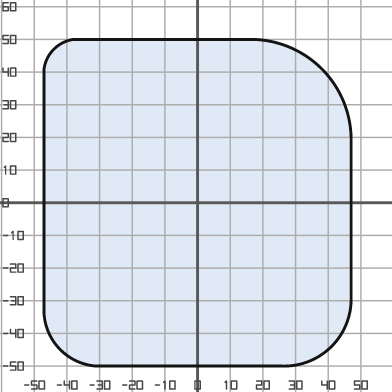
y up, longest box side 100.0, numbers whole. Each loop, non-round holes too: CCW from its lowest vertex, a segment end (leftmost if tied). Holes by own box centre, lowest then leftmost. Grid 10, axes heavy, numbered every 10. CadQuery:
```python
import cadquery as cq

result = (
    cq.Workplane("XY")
    .moveTo(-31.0, -50.0)
    .lineTo(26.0, -50.0)
    .threePointArc((41.0, -44.0), (47.0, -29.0))
    .lineTo(47.0, 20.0)
    .threePointArc((38.0, 41.0), (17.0, 50.0))
    .lineTo(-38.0, 50.0)
    .threePointArc((-44.0, 47.0), (-47.0, 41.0))
    .lineTo(-47.0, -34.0)
    .threePointArc((-42.0, -45.0), (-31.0, -50.0))
    .close()
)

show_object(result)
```